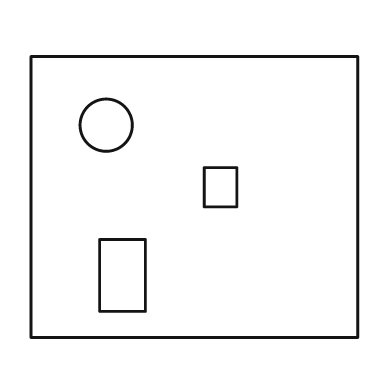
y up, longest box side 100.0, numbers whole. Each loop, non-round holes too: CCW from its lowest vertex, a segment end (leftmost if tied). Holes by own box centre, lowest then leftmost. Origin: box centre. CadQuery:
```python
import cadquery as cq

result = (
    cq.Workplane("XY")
    .moveTo(-50.0, -43.0)
    .lineTo(50.0, -43.0)
    .lineTo(50.0, 43.0)
    .lineTo(-50.0, 43.0)
    .close()
    .moveTo(-29.0, -35.0)
    .lineTo(-15.0, -35.0)
    .lineTo(-15.0, -13.0)
    .lineTo(-29.0, -13.0)
    .close()
    .moveTo(3.0, -3.0)
    .lineTo(13.0, -3.0)
    .lineTo(13.0, 9.0)
    .lineTo(3.0, 9.0)
    .close()
    .moveTo(-27.0, 22.0)
    .circle(8.0)
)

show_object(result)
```